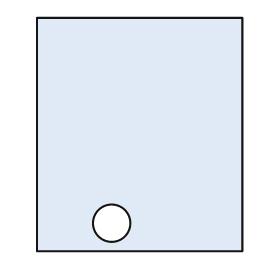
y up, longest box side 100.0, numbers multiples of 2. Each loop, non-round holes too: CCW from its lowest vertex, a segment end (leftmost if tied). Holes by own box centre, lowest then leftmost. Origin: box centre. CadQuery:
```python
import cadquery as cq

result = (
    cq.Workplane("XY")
    .moveTo(-44.0, -50.0)
    .lineTo(44.0, -50.0)
    .lineTo(44.0, 50.0)
    .lineTo(-44.0, 50.0)
    .close()
    .moveTo(-12.0, -38.0)
    .circle(8.0)
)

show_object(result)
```